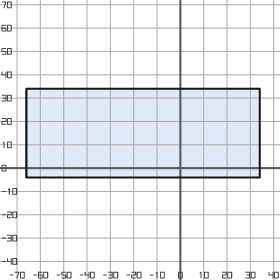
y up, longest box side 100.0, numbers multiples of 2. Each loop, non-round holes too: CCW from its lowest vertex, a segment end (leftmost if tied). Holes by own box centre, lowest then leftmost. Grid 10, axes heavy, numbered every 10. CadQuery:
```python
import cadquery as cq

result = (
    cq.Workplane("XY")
    .moveTo(-66.0, -4.0)
    .lineTo(34.0, -4.0)
    .lineTo(34.0, 34.0)
    .lineTo(-66.0, 34.0)
    .close()
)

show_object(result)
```